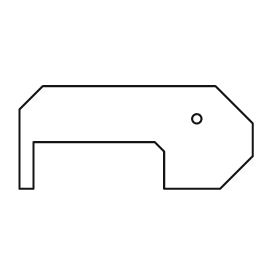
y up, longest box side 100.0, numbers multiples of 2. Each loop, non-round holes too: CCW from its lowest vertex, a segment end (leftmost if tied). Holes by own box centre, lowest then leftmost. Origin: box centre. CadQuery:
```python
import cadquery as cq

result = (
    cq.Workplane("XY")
    .moveTo(-50.0, -22.0)
    .lineTo(-44.0, -22.0)
    .lineTo(-44.0, -2.0)
    .lineTo(8.0, -2.0)
    .lineTo(12.0, -6.0)
    .lineTo(12.0, -22.0)
    .lineTo(36.0, -22.0)
    .lineTo(50.0, -8.0)
    .lineTo(50.0, 6.0)
    .lineTo(34.0, 22.0)
    .lineTo(-40.0, 22.0)
    .lineTo(-50.0, 12.0)
    .close()
    .moveTo(26.0, 8.0)
    .circle(2.0)
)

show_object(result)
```